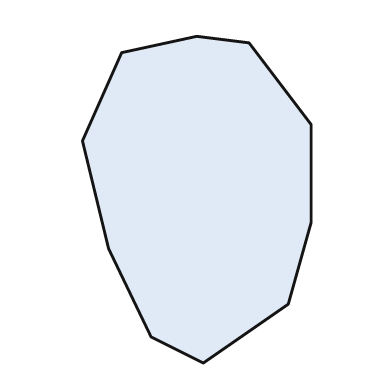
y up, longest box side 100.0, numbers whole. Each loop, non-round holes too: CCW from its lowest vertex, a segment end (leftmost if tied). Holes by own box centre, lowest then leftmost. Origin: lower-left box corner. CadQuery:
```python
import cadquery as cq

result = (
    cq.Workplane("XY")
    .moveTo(37.0, 0.0)
    .lineTo(63.0, 18.0)
    .lineTo(70.0, 43.0)
    .lineTo(70.0, 73.0)
    .lineTo(51.0, 98.0)
    .lineTo(35.0, 100.0)
    .lineTo(12.0, 95.0)
    .lineTo(0.0, 68.0)
    .lineTo(8.0, 35.0)
    .lineTo(21.0, 8.0)
    .close()
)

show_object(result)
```